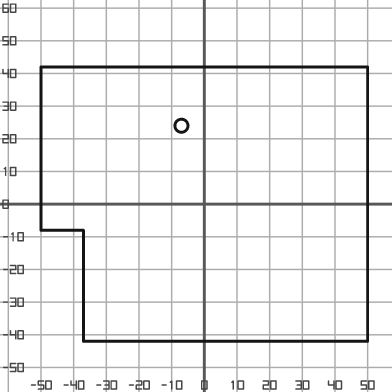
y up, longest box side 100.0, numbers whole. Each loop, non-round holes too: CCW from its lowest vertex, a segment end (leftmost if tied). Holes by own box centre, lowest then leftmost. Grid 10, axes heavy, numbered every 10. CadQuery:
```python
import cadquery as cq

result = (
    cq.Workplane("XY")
    .moveTo(-37.0, -42.0)
    .lineTo(50.0, -42.0)
    .lineTo(50.0, 42.0)
    .lineTo(-50.0, 42.0)
    .lineTo(-50.0, -8.0)
    .lineTo(-37.0, -8.0)
    .close()
    .moveTo(-7.0, 24.0)
    .circle(2.0)
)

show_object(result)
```